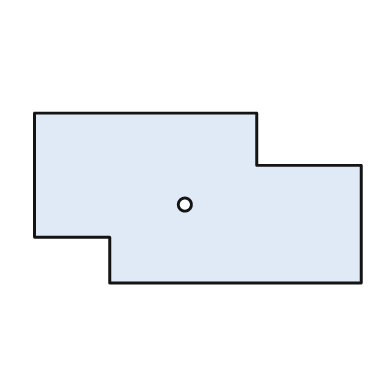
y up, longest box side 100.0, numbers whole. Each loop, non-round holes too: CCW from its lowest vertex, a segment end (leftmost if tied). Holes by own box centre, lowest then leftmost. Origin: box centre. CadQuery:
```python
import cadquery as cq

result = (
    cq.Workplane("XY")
    .moveTo(-27.0, -26.0)
    .lineTo(50.0, -26.0)
    .lineTo(50.0, 10.0)
    .lineTo(18.0, 10.0)
    .lineTo(18.0, 26.0)
    .lineTo(-50.0, 26.0)
    .lineTo(-50.0, -12.0)
    .lineTo(-27.0, -12.0)
    .close()
    .moveTo(-4.0, -2.0)
    .circle(2.0)
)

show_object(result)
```